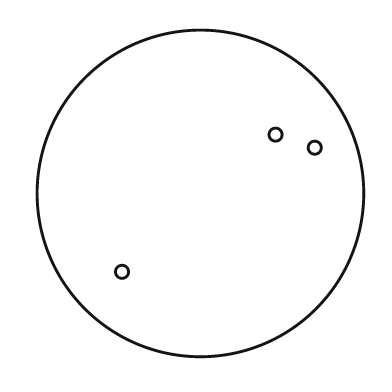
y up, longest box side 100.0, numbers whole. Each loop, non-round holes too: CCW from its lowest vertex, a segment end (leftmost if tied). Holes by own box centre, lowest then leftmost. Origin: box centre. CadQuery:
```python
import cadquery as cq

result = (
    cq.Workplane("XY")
    .moveTo(0.0, 0.0)
    .circle(50.0)
    .moveTo(-24.0, -24.0)
    .circle(2.0)
    .moveTo(35.0, 14.0)
    .circle(2.0)
    .moveTo(23.0, 18.0)
    .circle(2.0)
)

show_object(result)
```